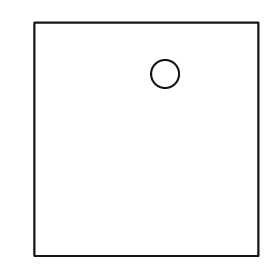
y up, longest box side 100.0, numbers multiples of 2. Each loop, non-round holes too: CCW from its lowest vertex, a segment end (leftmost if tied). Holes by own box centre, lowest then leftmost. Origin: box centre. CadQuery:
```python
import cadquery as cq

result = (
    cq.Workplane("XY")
    .moveTo(-48.0, -50.0)
    .lineTo(48.0, -50.0)
    .lineTo(48.0, 50.0)
    .lineTo(-48.0, 50.0)
    .close()
    .moveTo(8.0, 28.0)
    .circle(6.0)
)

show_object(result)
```